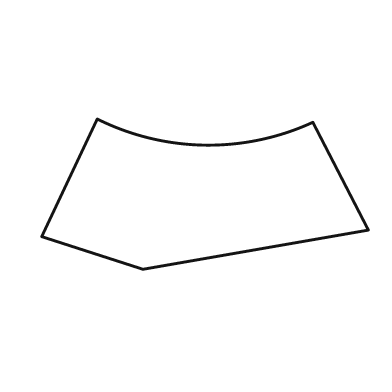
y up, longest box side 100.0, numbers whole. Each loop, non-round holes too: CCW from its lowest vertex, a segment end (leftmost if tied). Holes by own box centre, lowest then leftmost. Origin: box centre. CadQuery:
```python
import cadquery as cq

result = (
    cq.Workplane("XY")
    .moveTo(-19.0, -23.0)
    .lineTo(50.0, -11.0)
    .lineTo(33.0, 22.0)
    .threePointArc((0.0, 15.0), (-33.0, 23.0))
    .lineTo(-50.0, -13.0)
    .close()
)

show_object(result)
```